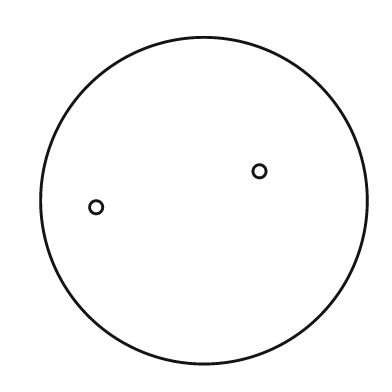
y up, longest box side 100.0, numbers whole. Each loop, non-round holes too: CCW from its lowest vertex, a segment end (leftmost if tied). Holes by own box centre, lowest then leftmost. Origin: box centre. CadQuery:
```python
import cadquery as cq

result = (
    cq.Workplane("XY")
    .moveTo(0.0, 0.0)
    .circle(50.0)
    .moveTo(-33.0, -2.0)
    .circle(2.0)
    .moveTo(17.0, 9.0)
    .circle(2.0)
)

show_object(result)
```